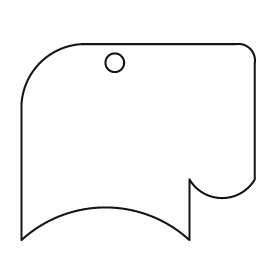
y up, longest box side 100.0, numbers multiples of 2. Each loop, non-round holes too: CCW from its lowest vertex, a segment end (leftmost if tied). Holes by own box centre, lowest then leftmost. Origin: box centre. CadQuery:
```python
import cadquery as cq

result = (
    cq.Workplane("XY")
    .moveTo(-50.0, -42.0)
    .threePointArc((-14.0, -28.0), (22.0, -42.0))
    .lineTo(22.0, -16.0)
    .threePointArc((36.0, -24.0), (50.0, -16.0))
    .lineTo(50.0, 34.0)
    .threePointArc((48.0, 40.0), (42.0, 42.0))
    .lineTo(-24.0, 42.0)
    .threePointArc((-42.0, 34.0), (-50.0, 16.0))
    .close()
    .moveTo(-10.0, 34.0)
    .circle(4.0)
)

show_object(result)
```